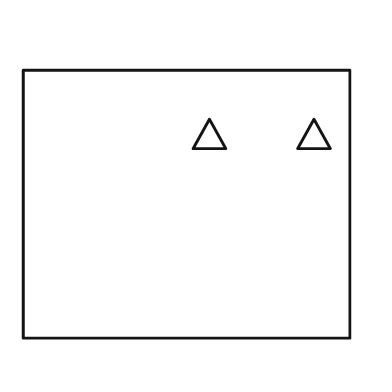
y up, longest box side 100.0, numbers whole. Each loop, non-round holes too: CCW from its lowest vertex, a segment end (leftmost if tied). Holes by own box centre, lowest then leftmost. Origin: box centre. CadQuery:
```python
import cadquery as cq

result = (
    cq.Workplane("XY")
    .moveTo(-50.0, -41.0)
    .lineTo(50.0, -41.0)
    .lineTo(50.0, 41.0)
    .lineTo(-50.0, 41.0)
    .close()
    .moveTo(2.0, 17.0)
    .lineTo(12.0, 17.0)
    .lineTo(7.0, 26.0)
    .close()
    .moveTo(34.0, 17.0)
    .lineTo(44.0, 17.0)
    .lineTo(39.0, 26.0)
    .close()
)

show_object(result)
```